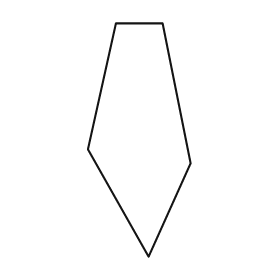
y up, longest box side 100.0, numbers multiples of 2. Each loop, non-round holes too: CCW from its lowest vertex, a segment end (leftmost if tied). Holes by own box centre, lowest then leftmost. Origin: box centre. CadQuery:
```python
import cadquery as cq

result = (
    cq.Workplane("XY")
    .moveTo(4.0, -50.0)
    .lineTo(22.0, -10.0)
    .lineTo(10.0, 50.0)
    .lineTo(-10.0, 50.0)
    .lineTo(-22.0, -4.0)
    .close()
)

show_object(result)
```